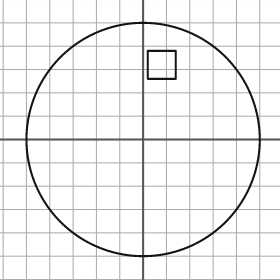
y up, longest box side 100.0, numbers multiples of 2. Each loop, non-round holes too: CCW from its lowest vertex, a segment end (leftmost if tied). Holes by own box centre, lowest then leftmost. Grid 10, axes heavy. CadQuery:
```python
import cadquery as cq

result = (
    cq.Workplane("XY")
    .moveTo(0.0, 0.0)
    .circle(50.0)
    .moveTo(2.0, 26.0)
    .lineTo(14.0, 26.0)
    .lineTo(14.0, 38.0)
    .lineTo(2.0, 38.0)
    .close()
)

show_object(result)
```